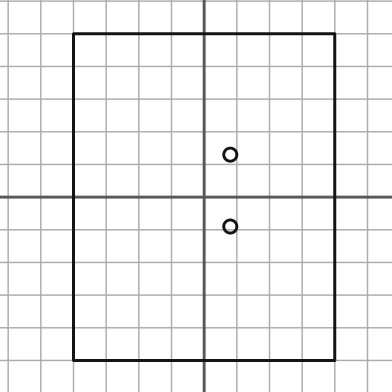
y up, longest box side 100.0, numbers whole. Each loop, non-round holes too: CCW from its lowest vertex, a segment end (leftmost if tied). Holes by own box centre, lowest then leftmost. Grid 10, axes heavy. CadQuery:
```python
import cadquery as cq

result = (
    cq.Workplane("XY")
    .moveTo(-40.0, -50.0)
    .lineTo(40.0, -50.0)
    .lineTo(40.0, 50.0)
    .lineTo(-40.0, 50.0)
    .close()
    .moveTo(8.0, -9.0)
    .circle(2.0)
    .moveTo(8.0, 13.0)
    .circle(2.0)
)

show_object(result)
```